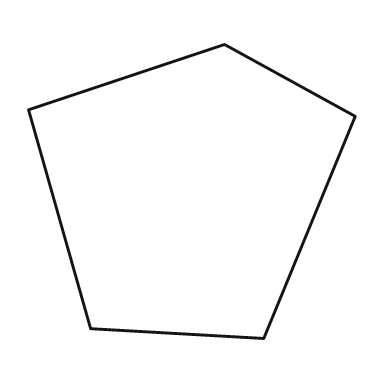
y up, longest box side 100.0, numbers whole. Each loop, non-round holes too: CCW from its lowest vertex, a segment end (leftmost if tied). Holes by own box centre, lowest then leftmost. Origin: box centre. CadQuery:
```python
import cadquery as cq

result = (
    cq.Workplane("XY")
    .moveTo(22.0, -45.0)
    .lineTo(50.0, 23.0)
    .lineTo(10.0, 45.0)
    .lineTo(-50.0, 25.0)
    .lineTo(-31.0, -42.0)
    .close()
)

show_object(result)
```